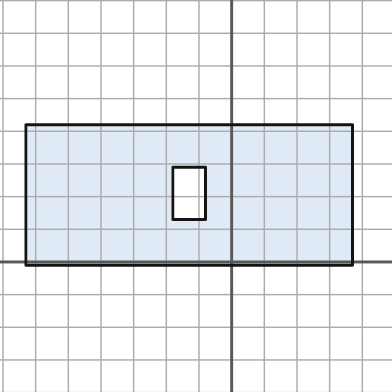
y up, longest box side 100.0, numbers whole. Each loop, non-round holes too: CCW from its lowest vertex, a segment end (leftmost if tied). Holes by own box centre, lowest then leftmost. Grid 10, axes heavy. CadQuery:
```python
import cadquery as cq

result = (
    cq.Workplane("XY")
    .moveTo(-63.0, -1.0)
    .lineTo(37.0, -1.0)
    .lineTo(37.0, 42.0)
    .lineTo(-63.0, 42.0)
    .close()
    .moveTo(-18.0, 13.0)
    .lineTo(-8.0, 13.0)
    .lineTo(-8.0, 29.0)
    .lineTo(-18.0, 29.0)
    .close()
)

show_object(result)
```